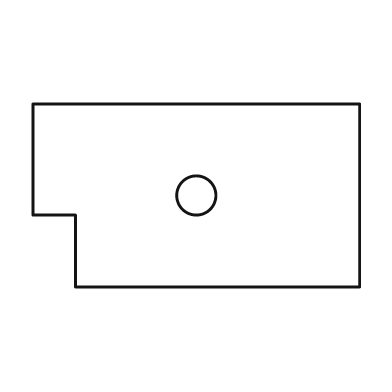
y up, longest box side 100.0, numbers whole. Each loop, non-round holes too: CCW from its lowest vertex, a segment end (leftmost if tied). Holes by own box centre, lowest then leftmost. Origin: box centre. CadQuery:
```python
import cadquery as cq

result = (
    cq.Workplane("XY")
    .moveTo(-37.0, -28.0)
    .lineTo(50.0, -28.0)
    .lineTo(50.0, 28.0)
    .lineTo(-50.0, 28.0)
    .lineTo(-50.0, -6.0)
    .lineTo(-37.0, -6.0)
    .close()
    .moveTo(0.0, 0.0)
    .circle(6.0)
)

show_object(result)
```